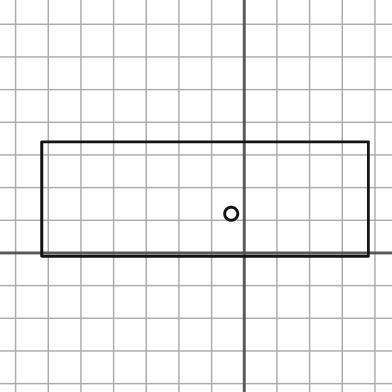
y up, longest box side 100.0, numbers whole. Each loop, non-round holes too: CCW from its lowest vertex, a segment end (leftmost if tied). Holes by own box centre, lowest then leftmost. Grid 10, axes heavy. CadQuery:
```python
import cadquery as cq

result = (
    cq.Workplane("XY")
    .moveTo(-62.0, -1.0)
    .lineTo(38.0, -1.0)
    .lineTo(38.0, 34.0)
    .lineTo(-62.0, 34.0)
    .close()
    .moveTo(-4.0, 12.0)
    .circle(2.0)
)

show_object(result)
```